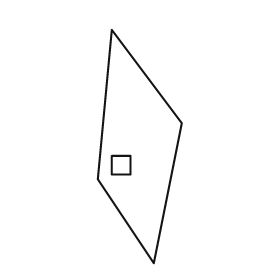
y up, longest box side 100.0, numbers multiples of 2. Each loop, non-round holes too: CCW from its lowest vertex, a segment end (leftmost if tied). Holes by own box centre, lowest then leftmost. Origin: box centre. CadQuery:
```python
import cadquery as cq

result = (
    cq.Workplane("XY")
    .moveTo(6.0, -50.0)
    .lineTo(18.0, 10.0)
    .lineTo(-12.0, 50.0)
    .lineTo(-18.0, -14.0)
    .close()
    .moveTo(-12.0, -12.0)
    .lineTo(-4.0, -12.0)
    .lineTo(-4.0, -4.0)
    .lineTo(-12.0, -4.0)
    .close()
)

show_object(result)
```